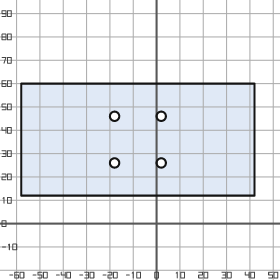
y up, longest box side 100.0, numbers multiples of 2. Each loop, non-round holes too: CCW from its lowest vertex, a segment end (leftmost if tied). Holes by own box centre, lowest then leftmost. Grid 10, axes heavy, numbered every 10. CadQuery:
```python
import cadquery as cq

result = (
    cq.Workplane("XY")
    .moveTo(-58.0, 12.0)
    .lineTo(42.0, 12.0)
    .lineTo(42.0, 60.0)
    .lineTo(-58.0, 60.0)
    .close()
    .moveTo(-18.0, 26.0)
    .circle(2.0)
    .moveTo(2.0, 26.0)
    .circle(2.0)
    .moveTo(-18.0, 46.0)
    .circle(2.0)
    .moveTo(2.0, 46.0)
    .circle(2.0)
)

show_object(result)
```